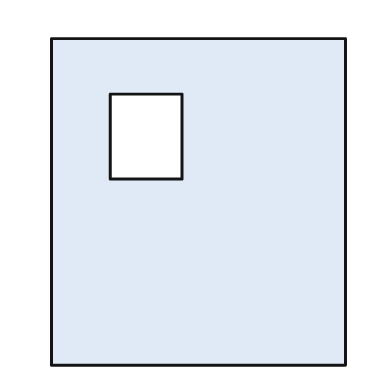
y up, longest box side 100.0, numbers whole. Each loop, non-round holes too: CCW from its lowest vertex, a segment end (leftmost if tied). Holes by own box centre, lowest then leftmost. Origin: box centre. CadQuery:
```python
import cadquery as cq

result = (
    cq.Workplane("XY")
    .moveTo(-45.0, -50.0)
    .lineTo(45.0, -50.0)
    .lineTo(45.0, 50.0)
    .lineTo(-45.0, 50.0)
    .close()
    .moveTo(-27.0, 7.0)
    .lineTo(-5.0, 7.0)
    .lineTo(-5.0, 33.0)
    .lineTo(-27.0, 33.0)
    .close()
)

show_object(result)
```